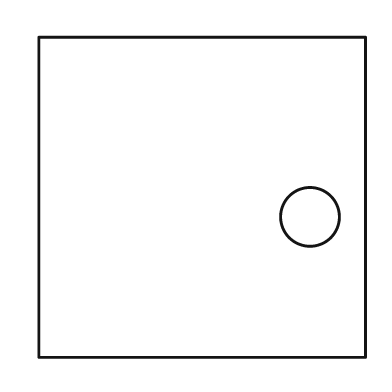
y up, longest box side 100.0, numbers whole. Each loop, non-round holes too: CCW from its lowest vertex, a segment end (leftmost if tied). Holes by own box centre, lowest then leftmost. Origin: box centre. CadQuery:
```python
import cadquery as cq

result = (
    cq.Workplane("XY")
    .moveTo(-50.0, -49.0)
    .lineTo(50.0, -49.0)
    .lineTo(50.0, 49.0)
    .lineTo(-50.0, 49.0)
    .close()
    .moveTo(33.0, -6.0)
    .circle(9.0)
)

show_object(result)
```